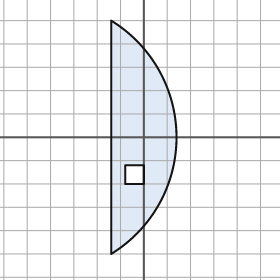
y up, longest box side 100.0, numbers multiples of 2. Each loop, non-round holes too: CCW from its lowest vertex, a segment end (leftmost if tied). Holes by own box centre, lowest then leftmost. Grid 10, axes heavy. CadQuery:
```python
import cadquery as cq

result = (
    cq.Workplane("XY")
    .moveTo(-14.0, -50.0)
    .threePointArc((14.0, 0.0), (-14.0, 50.0))
    .close()
    .moveTo(-8.0, -20.0)
    .lineTo(0.0, -20.0)
    .lineTo(0.0, -12.0)
    .lineTo(-8.0, -12.0)
    .close()
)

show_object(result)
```